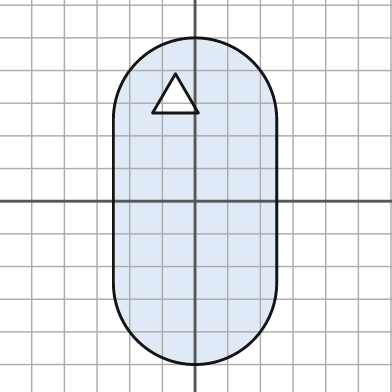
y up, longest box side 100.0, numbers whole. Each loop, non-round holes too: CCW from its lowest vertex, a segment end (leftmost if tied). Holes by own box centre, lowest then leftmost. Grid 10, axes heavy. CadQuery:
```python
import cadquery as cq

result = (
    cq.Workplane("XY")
    .moveTo(-25.0, -25.0)
    .threePointArc((0.0, -50.0), (25.0, -25.0))
    .lineTo(25.0, 25.0)
    .threePointArc((0.0, 50.0), (-25.0, 25.0))
    .close()
    .moveTo(-13.0, 27.0)
    .lineTo(1.0, 27.0)
    .lineTo(-6.0, 39.0)
    .close()
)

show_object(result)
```